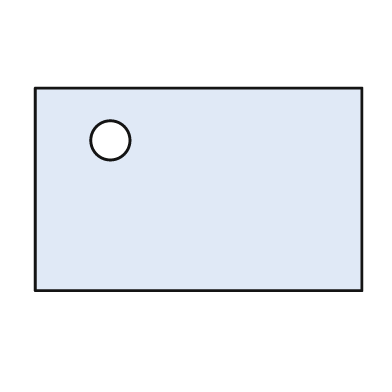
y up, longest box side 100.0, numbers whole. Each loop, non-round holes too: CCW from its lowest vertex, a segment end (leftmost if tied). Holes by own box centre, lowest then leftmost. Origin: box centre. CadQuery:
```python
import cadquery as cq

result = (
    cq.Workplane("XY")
    .moveTo(-50.0, -31.0)
    .lineTo(50.0, -31.0)
    .lineTo(50.0, 31.0)
    .lineTo(-50.0, 31.0)
    .close()
    .moveTo(-27.0, 15.0)
    .circle(6.0)
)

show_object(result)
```